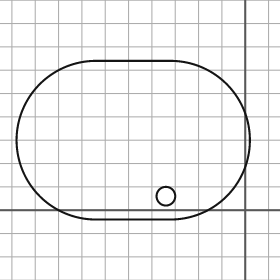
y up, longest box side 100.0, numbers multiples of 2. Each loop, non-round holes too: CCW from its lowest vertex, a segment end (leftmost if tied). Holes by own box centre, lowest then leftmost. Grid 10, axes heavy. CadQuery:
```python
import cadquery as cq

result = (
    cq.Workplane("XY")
    .moveTo(-64.0, -4.0)
    .lineTo(-32.0, -4.0)
    .threePointArc((2.0, 30.0), (-32.0, 64.0))
    .lineTo(-64.0, 64.0)
    .threePointArc((-98.0, 30.0), (-64.0, -4.0))
    .close()
    .moveTo(-34.0, 6.0)
    .circle(4.0)
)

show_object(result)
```